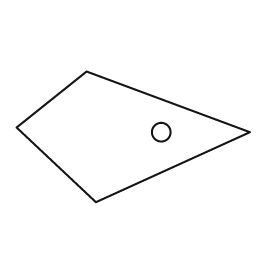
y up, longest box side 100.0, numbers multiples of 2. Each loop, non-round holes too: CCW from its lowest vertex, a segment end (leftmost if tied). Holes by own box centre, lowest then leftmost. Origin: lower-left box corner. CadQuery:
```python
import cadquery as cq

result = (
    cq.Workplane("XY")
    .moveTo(34.0, 0.0)
    .lineTo(100.0, 30.0)
    .lineTo(30.0, 56.0)
    .lineTo(0.0, 32.0)
    .close()
    .moveTo(62.0, 30.0)
    .circle(4.0)
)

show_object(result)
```